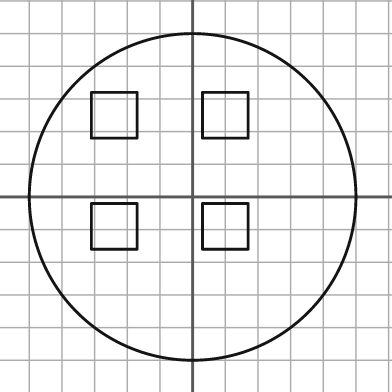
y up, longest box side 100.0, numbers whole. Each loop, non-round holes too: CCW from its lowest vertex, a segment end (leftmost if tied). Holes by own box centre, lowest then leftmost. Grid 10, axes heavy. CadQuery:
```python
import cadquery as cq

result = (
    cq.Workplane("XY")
    .moveTo(0.0, 0.0)
    .circle(50.0)
    .moveTo(-31.0, -16.0)
    .lineTo(-17.0, -16.0)
    .lineTo(-17.0, -2.0)
    .lineTo(-31.0, -2.0)
    .close()
    .moveTo(3.0, -16.0)
    .lineTo(17.0, -16.0)
    .lineTo(17.0, -2.0)
    .lineTo(3.0, -2.0)
    .close()
    .moveTo(-31.0, 18.0)
    .lineTo(-17.0, 18.0)
    .lineTo(-17.0, 32.0)
    .lineTo(-31.0, 32.0)
    .close()
    .moveTo(3.0, 18.0)
    .lineTo(17.0, 18.0)
    .lineTo(17.0, 32.0)
    .lineTo(3.0, 32.0)
    .close()
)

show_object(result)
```